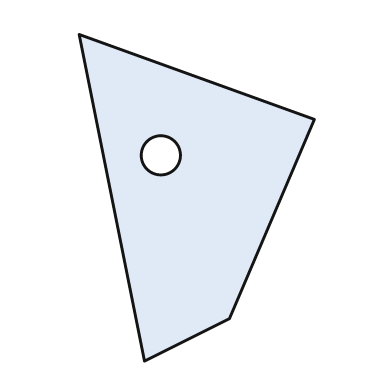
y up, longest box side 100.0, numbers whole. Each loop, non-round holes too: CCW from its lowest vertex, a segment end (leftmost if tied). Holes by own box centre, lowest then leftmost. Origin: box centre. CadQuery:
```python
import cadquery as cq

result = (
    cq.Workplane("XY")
    .moveTo(-16.0, -50.0)
    .lineTo(10.0, -37.0)
    .lineTo(36.0, 24.0)
    .lineTo(-36.0, 50.0)
    .close()
    .moveTo(-11.0, 13.0)
    .circle(6.0)
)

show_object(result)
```